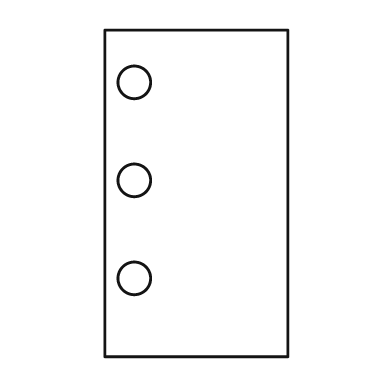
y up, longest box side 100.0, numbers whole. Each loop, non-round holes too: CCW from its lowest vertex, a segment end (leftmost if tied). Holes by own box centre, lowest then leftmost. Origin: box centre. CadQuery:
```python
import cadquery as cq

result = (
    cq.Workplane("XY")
    .moveTo(-28.0, -50.0)
    .lineTo(28.0, -50.0)
    .lineTo(28.0, 50.0)
    .lineTo(-28.0, 50.0)
    .close()
    .moveTo(-19.0, -26.0)
    .circle(5.0)
    .moveTo(-19.0, 4.0)
    .circle(5.0)
    .moveTo(-19.0, 34.0)
    .circle(5.0)
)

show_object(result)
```